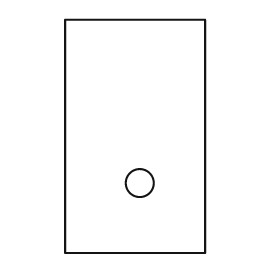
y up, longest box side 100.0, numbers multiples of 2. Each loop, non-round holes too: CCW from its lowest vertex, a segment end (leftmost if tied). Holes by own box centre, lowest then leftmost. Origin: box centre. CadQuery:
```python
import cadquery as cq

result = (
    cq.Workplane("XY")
    .moveTo(-30.0, -50.0)
    .lineTo(30.0, -50.0)
    .lineTo(30.0, 50.0)
    .lineTo(-30.0, 50.0)
    .close()
    .moveTo(2.0, -20.0)
    .circle(6.0)
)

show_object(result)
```